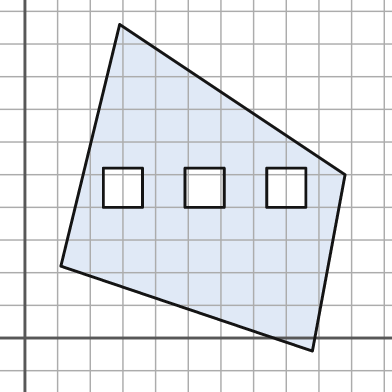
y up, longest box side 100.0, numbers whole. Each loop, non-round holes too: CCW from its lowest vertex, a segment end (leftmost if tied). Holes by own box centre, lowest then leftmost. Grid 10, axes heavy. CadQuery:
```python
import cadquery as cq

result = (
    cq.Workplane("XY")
    .moveTo(88.0, -4.0)
    .lineTo(98.0, 50.0)
    .lineTo(29.0, 96.0)
    .lineTo(11.0, 22.0)
    .close()
    .moveTo(24.0, 40.0)
    .lineTo(36.0, 40.0)
    .lineTo(36.0, 52.0)
    .lineTo(24.0, 52.0)
    .close()
    .moveTo(49.0, 40.0)
    .lineTo(61.0, 40.0)
    .lineTo(61.0, 52.0)
    .lineTo(49.0, 52.0)
    .close()
    .moveTo(74.0, 40.0)
    .lineTo(86.0, 40.0)
    .lineTo(86.0, 52.0)
    .lineTo(74.0, 52.0)
    .close()
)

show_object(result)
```